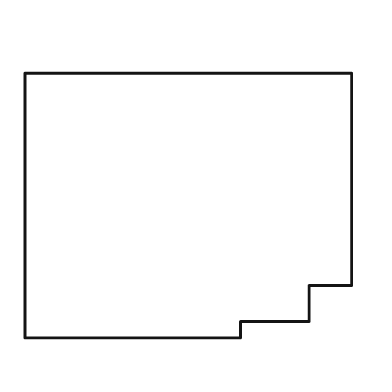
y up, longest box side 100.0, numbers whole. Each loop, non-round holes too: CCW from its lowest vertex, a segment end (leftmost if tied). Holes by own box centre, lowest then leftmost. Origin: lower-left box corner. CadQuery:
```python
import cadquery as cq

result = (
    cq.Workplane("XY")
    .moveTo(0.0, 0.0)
    .lineTo(66.0, 0.0)
    .lineTo(66.0, 5.0)
    .lineTo(87.0, 5.0)
    .lineTo(87.0, 16.0)
    .lineTo(100.0, 16.0)
    .lineTo(100.0, 81.0)
    .lineTo(0.0, 81.0)
    .close()
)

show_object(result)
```